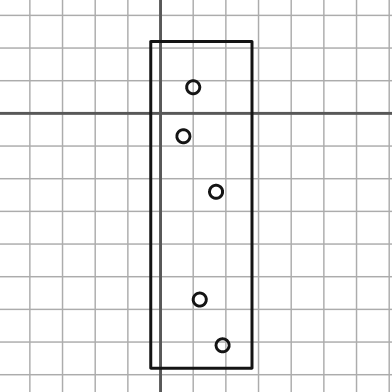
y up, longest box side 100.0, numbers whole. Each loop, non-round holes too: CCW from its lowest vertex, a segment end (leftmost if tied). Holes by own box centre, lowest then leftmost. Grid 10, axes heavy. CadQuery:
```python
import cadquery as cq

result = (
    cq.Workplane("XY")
    .moveTo(-3.0, -78.0)
    .lineTo(28.0, -78.0)
    .lineTo(28.0, 22.0)
    .lineTo(-3.0, 22.0)
    .close()
    .moveTo(19.0, -71.0)
    .circle(2.0)
    .moveTo(12.0, -57.0)
    .circle(2.0)
    .moveTo(17.0, -24.0)
    .circle(2.0)
    .moveTo(7.0, -7.0)
    .circle(2.0)
    .moveTo(10.0, 8.0)
    .circle(2.0)
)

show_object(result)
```